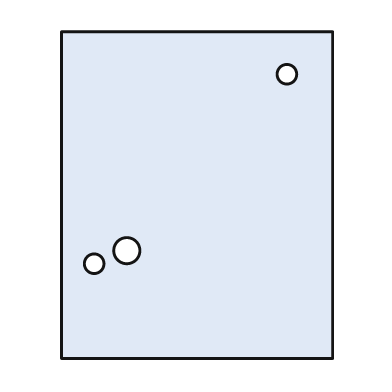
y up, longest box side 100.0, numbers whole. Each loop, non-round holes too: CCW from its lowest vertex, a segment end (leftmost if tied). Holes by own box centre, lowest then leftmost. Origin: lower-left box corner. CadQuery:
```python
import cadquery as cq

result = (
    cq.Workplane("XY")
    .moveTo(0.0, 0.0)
    .lineTo(83.0, 0.0)
    .lineTo(83.0, 100.0)
    .lineTo(0.0, 100.0)
    .close()
    .moveTo(10.0, 29.0)
    .circle(3.0)
    .moveTo(20.0, 33.0)
    .circle(4.0)
    .moveTo(69.0, 87.0)
    .circle(3.0)
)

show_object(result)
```